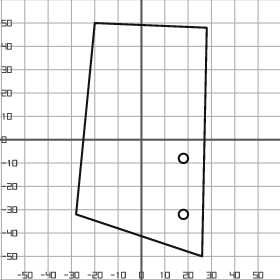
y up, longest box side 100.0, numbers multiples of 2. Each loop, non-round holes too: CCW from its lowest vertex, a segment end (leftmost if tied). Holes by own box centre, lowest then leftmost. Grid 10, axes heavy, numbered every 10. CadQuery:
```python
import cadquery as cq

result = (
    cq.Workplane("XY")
    .moveTo(26.0, -50.0)
    .lineTo(28.0, 48.0)
    .lineTo(-20.0, 50.0)
    .lineTo(-28.0, -32.0)
    .close()
    .moveTo(18.0, -32.0)
    .circle(2.0)
    .moveTo(18.0, -8.0)
    .circle(2.0)
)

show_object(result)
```